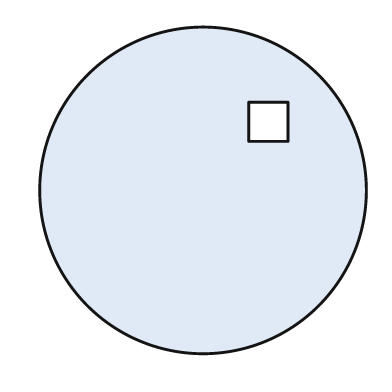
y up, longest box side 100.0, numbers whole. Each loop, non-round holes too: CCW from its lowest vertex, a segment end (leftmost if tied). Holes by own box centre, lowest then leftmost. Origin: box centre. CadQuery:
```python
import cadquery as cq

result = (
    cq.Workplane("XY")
    .moveTo(0.0, 0.0)
    .circle(50.0)
    .moveTo(14.0, 15.0)
    .lineTo(26.0, 15.0)
    .lineTo(26.0, 27.0)
    .lineTo(14.0, 27.0)
    .close()
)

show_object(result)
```